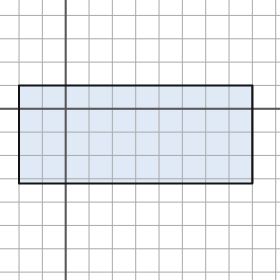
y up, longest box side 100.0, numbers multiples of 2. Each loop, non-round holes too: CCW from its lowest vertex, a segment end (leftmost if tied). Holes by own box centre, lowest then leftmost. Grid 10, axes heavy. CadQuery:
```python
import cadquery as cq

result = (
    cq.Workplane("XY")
    .moveTo(-20.0, -32.0)
    .lineTo(80.0, -32.0)
    .lineTo(80.0, 10.0)
    .lineTo(-20.0, 10.0)
    .close()
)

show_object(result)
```